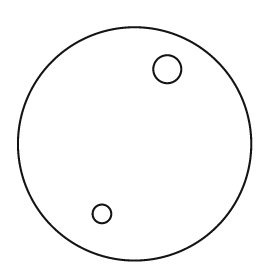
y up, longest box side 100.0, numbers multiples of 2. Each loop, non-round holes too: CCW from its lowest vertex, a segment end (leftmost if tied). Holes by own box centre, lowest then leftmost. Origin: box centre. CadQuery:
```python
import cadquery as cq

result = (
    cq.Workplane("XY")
    .moveTo(0.0, 0.0)
    .circle(50.0)
    .moveTo(-14.0, -30.0)
    .circle(4.0)
    .moveTo(14.0, 32.0)
    .circle(6.0)
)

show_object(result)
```